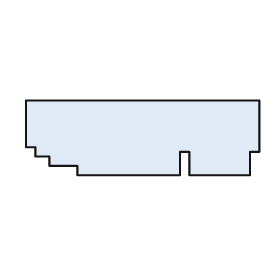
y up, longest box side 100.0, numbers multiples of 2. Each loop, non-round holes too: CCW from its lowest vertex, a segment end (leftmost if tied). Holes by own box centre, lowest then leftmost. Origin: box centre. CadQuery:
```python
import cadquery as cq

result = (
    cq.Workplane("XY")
    .moveTo(-28.0, -16.0)
    .lineTo(16.0, -16.0)
    .lineTo(16.0, -6.0)
    .lineTo(20.0, -6.0)
    .lineTo(20.0, -16.0)
    .lineTo(46.0, -16.0)
    .lineTo(46.0, -6.0)
    .lineTo(50.0, -6.0)
    .lineTo(50.0, 16.0)
    .lineTo(-50.0, 16.0)
    .lineTo(-50.0, -4.0)
    .lineTo(-46.0, -4.0)
    .lineTo(-46.0, -8.0)
    .lineTo(-40.0, -8.0)
    .lineTo(-40.0, -12.0)
    .lineTo(-28.0, -12.0)
    .close()
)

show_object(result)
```